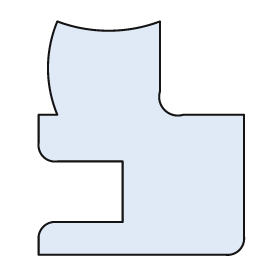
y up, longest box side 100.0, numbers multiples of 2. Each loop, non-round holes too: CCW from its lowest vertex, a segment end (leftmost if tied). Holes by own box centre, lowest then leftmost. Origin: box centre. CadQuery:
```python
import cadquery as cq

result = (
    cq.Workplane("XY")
    .moveTo(-44.0, -50.0)
    .lineTo(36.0, -50.0)
    .threePointArc((42.0, -48.0), (44.0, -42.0))
    .lineTo(44.0, 10.0)
    .lineTo(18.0, 10.0)
    .threePointArc((10.0, 12.0), (8.0, 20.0))
    .lineTo(8.0, 50.0)
    .threePointArc((-14.0, 46.0), (-36.0, 50.0))
    .threePointArc((-40.0, 30.0), (-36.0, 10.0))
    .lineTo(-44.0, 10.0)
    .lineTo(-44.0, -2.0)
    .threePointArc((-42.0, -8.0), (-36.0, -10.0))
    .lineTo(-8.0, -10.0)
    .lineTo(-8.0, -36.0)
    .lineTo(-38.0, -36.0)
    .threePointArc((-42.0, -38.0), (-44.0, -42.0))
    .close()
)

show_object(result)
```